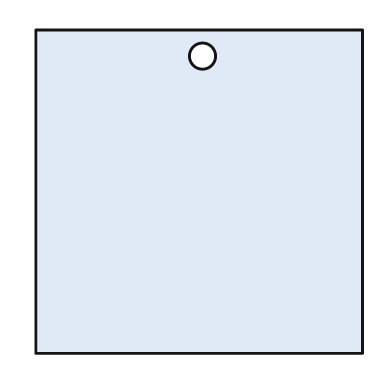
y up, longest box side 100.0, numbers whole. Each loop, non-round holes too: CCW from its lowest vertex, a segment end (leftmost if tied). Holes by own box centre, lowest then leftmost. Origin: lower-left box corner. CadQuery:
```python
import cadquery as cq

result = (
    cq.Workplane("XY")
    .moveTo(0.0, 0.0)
    .lineTo(100.0, 0.0)
    .lineTo(100.0, 99.0)
    .lineTo(0.0, 99.0)
    .close()
    .moveTo(51.0, 91.0)
    .circle(4.0)
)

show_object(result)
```